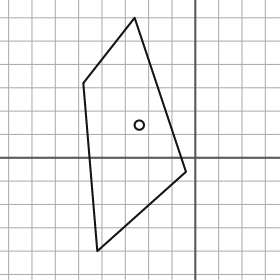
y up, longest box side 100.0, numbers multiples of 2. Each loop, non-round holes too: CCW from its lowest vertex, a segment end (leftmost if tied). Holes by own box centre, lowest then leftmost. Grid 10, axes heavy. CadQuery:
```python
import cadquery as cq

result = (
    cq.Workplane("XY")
    .moveTo(-42.0, -40.0)
    .lineTo(-4.0, -6.0)
    .lineTo(-26.0, 60.0)
    .lineTo(-48.0, 32.0)
    .close()
    .moveTo(-24.0, 14.0)
    .circle(2.0)
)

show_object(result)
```